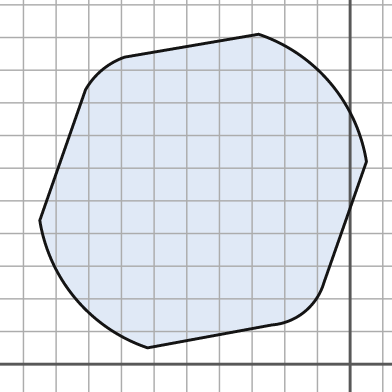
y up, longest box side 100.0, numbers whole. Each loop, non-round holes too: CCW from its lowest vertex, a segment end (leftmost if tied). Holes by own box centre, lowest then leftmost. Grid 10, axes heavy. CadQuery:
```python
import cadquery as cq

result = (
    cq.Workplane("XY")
    .moveTo(-62.0, 5.0)
    .lineTo(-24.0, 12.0)
    .threePointArc((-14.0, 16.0), (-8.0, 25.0))
    .lineTo(5.0, 62.0)
    .threePointArc((-6.0, 86.0), (-28.0, 101.0))
    .lineTo(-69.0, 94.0)
    .threePointArc((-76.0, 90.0), (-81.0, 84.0))
    .lineTo(-95.0, 44.0)
    .threePointArc((-84.0, 20.0), (-62.0, 5.0))
    .close()
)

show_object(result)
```